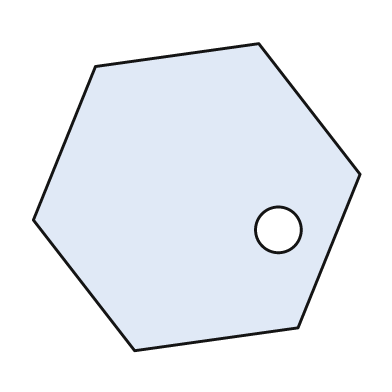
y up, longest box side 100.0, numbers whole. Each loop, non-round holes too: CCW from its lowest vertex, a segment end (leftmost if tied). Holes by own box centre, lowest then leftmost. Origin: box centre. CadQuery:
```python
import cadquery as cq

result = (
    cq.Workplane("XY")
    .moveTo(-19.0, -47.0)
    .lineTo(31.0, -40.0)
    .lineTo(50.0, 7.0)
    .lineTo(19.0, 47.0)
    .lineTo(-31.0, 40.0)
    .lineTo(-50.0, -7.0)
    .close()
    .moveTo(25.0, -10.0)
    .circle(7.0)
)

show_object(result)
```